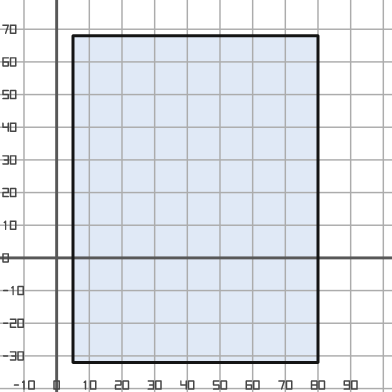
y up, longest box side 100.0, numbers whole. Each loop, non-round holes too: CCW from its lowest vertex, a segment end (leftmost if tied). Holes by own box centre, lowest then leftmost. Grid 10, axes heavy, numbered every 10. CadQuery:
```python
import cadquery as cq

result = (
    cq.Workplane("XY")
    .moveTo(5.0, -32.0)
    .lineTo(80.0, -32.0)
    .lineTo(80.0, 68.0)
    .lineTo(5.0, 68.0)
    .close()
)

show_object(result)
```